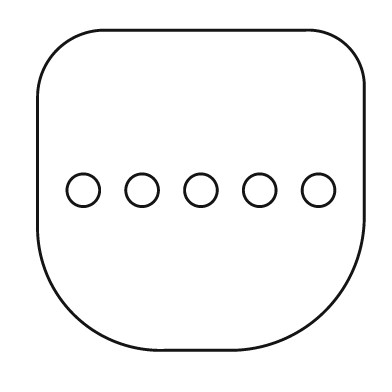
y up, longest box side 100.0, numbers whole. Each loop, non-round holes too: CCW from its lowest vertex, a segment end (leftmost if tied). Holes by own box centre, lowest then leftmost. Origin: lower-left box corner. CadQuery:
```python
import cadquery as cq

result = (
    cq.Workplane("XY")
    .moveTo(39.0, 0.0)
    .lineTo(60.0, 0.0)
    .threePointArc((88.0, 12.0), (100.0, 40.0))
    .lineTo(100.0, 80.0)
    .threePointArc((95.0, 93.0), (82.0, 98.0))
    .lineTo(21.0, 98.0)
    .threePointArc((6.0, 92.0), (0.0, 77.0))
    .lineTo(0.0, 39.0)
    .threePointArc((11.0, 11.0), (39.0, 0.0))
    .close()
    .moveTo(14.0, 49.0)
    .circle(5.0)
    .moveTo(32.0, 49.0)
    .circle(5.0)
    .moveTo(50.0, 49.0)
    .circle(5.0)
    .moveTo(68.0, 49.0)
    .circle(5.0)
    .moveTo(86.0, 49.0)
    .circle(5.0)
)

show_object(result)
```